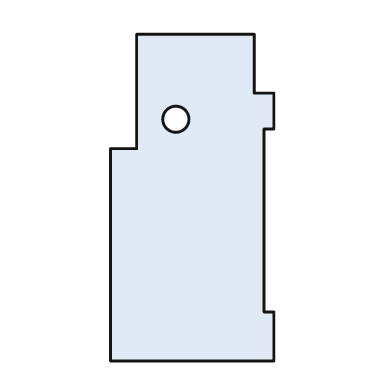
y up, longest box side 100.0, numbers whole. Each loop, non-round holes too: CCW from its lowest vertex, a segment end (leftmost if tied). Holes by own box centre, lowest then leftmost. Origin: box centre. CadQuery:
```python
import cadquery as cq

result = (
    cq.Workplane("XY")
    .moveTo(-25.0, -50.0)
    .lineTo(25.0, -50.0)
    .lineTo(25.0, -35.0)
    .lineTo(22.0, -35.0)
    .lineTo(22.0, 21.0)
    .lineTo(25.0, 21.0)
    .lineTo(25.0, 32.0)
    .lineTo(19.0, 32.0)
    .lineTo(19.0, 50.0)
    .lineTo(-17.0, 50.0)
    .lineTo(-17.0, 15.0)
    .lineTo(-25.0, 15.0)
    .close()
    .moveTo(-5.0, 24.0)
    .circle(4.0)
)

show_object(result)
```